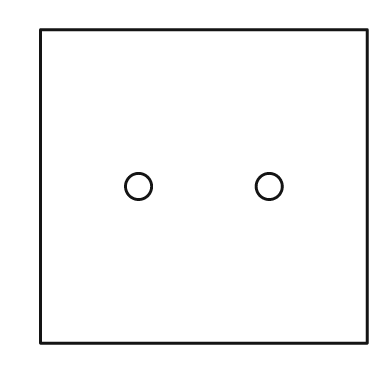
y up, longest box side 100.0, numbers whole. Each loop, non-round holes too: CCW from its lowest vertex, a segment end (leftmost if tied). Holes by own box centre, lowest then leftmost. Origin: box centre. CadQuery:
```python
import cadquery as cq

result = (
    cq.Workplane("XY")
    .moveTo(-50.0, -48.0)
    .lineTo(50.0, -48.0)
    .lineTo(50.0, 48.0)
    .lineTo(-50.0, 48.0)
    .close()
    .moveTo(-20.0, 0.0)
    .circle(4.0)
    .moveTo(20.0, 0.0)
    .circle(4.0)
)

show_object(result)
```